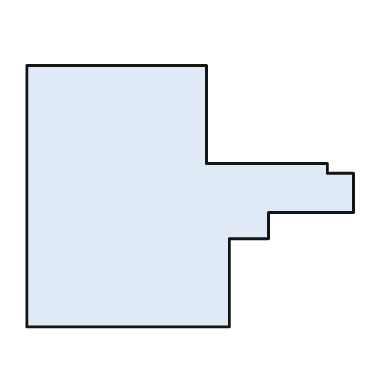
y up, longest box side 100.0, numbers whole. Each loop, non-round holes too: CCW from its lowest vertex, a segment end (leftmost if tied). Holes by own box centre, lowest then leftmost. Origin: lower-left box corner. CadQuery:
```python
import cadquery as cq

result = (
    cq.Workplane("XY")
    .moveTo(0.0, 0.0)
    .lineTo(62.0, 0.0)
    .lineTo(62.0, 27.0)
    .lineTo(74.0, 27.0)
    .lineTo(74.0, 35.0)
    .lineTo(100.0, 35.0)
    .lineTo(100.0, 47.0)
    .lineTo(92.0, 47.0)
    .lineTo(92.0, 50.0)
    .lineTo(55.0, 50.0)
    .lineTo(55.0, 80.0)
    .lineTo(0.0, 80.0)
    .close()
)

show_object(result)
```